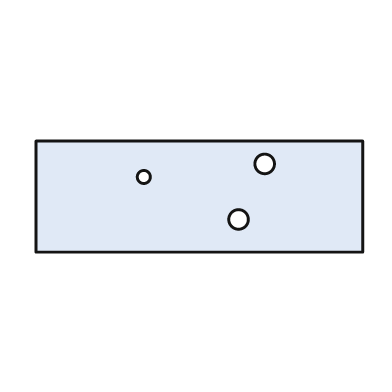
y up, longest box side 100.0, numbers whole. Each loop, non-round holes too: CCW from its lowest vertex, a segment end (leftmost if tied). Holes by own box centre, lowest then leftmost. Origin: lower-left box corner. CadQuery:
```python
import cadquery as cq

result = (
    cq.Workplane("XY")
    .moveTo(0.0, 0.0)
    .lineTo(100.0, 0.0)
    .lineTo(100.0, 34.0)
    .lineTo(0.0, 34.0)
    .close()
    .moveTo(62.0, 10.0)
    .circle(3.0)
    .moveTo(33.0, 23.0)
    .circle(2.0)
    .moveTo(70.0, 27.0)
    .circle(3.0)
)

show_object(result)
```